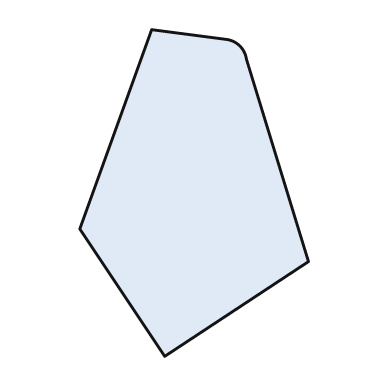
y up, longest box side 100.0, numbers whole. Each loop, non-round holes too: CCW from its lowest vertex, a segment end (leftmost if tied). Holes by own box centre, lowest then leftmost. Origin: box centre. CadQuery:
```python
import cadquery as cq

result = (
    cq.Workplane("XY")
    .moveTo(-9.0, -50.0)
    .lineTo(35.0, -21.0)
    .lineTo(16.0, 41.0)
    .threePointArc((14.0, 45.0), (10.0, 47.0))
    .lineTo(-13.0, 50.0)
    .lineTo(-35.0, -11.0)
    .close()
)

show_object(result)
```